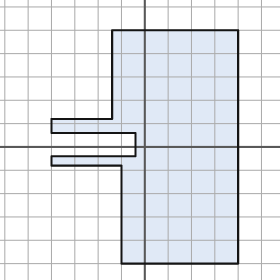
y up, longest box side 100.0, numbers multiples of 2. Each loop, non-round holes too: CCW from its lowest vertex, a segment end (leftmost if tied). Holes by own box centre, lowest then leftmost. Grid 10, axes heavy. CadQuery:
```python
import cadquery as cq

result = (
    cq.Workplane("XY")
    .moveTo(-10.0, -50.0)
    .lineTo(40.0, -50.0)
    .lineTo(40.0, 50.0)
    .lineTo(-14.0, 50.0)
    .lineTo(-14.0, 12.0)
    .lineTo(-40.0, 12.0)
    .lineTo(-40.0, 6.0)
    .lineTo(-4.0, 6.0)
    .lineTo(-4.0, -4.0)
    .lineTo(-40.0, -4.0)
    .lineTo(-40.0, -8.0)
    .lineTo(-10.0, -8.0)
    .close()
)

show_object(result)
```